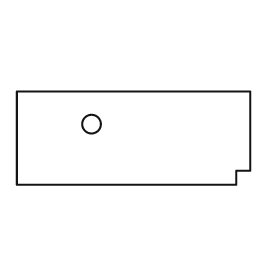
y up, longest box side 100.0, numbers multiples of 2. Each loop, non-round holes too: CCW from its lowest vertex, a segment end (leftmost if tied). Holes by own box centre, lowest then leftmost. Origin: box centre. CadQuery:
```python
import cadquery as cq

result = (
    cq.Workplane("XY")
    .moveTo(-50.0, -20.0)
    .lineTo(44.0, -20.0)
    .lineTo(44.0, -14.0)
    .lineTo(50.0, -14.0)
    .lineTo(50.0, 20.0)
    .lineTo(-50.0, 20.0)
    .close()
    .moveTo(-18.0, 6.0)
    .circle(4.0)
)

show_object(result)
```